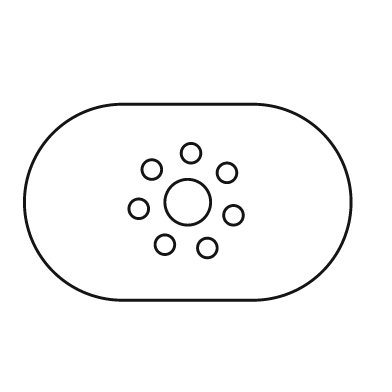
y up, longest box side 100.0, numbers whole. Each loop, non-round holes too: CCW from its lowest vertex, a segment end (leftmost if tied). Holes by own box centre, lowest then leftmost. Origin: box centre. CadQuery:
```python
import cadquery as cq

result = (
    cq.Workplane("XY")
    .moveTo(-20.0, -30.0)
    .lineTo(20.0, -30.0)
    .threePointArc((50.0, 0.0), (20.0, 30.0))
    .lineTo(-20.0, 30.0)
    .threePointArc((-50.0, 0.0), (-20.0, -30.0))
    .close()
    .moveTo(6.0, -14.0)
    .circle(3.0)
    .moveTo(-7.0, -13.0)
    .circle(3.0)
    .moveTo(14.0, -4.0)
    .circle(3.0)
    .moveTo(-15.0, -2.0)
    .circle(3.0)
    .moveTo(0.0, 0.0)
    .circle(7.0)
    .moveTo(12.0, 9.0)
    .circle(3.0)
    .moveTo(-11.0, 10.0)
    .circle(3.0)
    .moveTo(1.0, 15.0)
    .circle(3.0)
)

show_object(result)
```